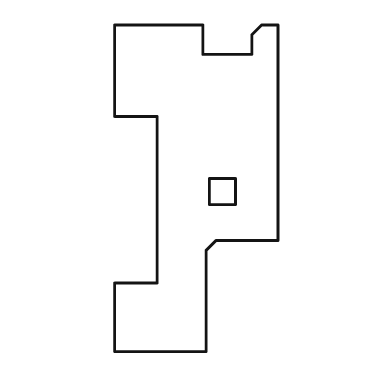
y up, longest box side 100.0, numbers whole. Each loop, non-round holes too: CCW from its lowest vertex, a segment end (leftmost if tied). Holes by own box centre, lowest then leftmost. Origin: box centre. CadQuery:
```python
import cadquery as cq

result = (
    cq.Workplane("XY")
    .moveTo(-25.0, -50.0)
    .lineTo(3.0, -50.0)
    .lineTo(3.0, -19.0)
    .lineTo(6.0, -16.0)
    .lineTo(25.0, -16.0)
    .lineTo(25.0, 50.0)
    .lineTo(20.0, 50.0)
    .lineTo(17.0, 47.0)
    .lineTo(17.0, 41.0)
    .lineTo(2.0, 41.0)
    .lineTo(2.0, 50.0)
    .lineTo(-25.0, 50.0)
    .lineTo(-25.0, 22.0)
    .lineTo(-12.0, 22.0)
    .lineTo(-12.0, -29.0)
    .lineTo(-25.0, -29.0)
    .close()
    .moveTo(4.0, -5.0)
    .lineTo(12.0, -5.0)
    .lineTo(12.0, 3.0)
    .lineTo(4.0, 3.0)
    .close()
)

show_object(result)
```